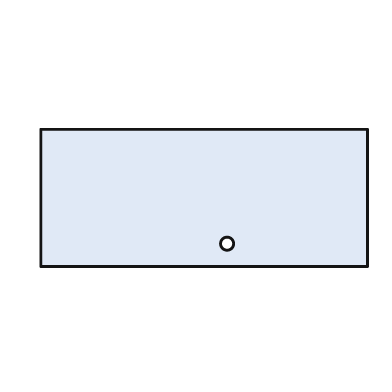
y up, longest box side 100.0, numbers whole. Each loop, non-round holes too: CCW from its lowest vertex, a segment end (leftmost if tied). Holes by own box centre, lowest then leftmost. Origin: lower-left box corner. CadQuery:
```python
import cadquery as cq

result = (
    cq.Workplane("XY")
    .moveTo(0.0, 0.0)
    .lineTo(100.0, 0.0)
    .lineTo(100.0, 42.0)
    .lineTo(0.0, 42.0)
    .close()
    .moveTo(57.0, 7.0)
    .circle(2.0)
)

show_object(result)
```